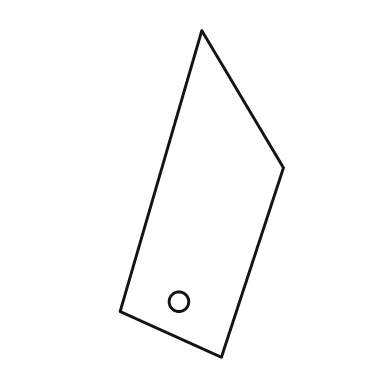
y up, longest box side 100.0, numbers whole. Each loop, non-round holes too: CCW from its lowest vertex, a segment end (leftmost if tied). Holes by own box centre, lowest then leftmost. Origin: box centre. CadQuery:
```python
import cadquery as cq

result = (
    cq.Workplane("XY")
    .moveTo(6.0, -50.0)
    .lineTo(25.0, 8.0)
    .lineTo(0.0, 50.0)
    .lineTo(-25.0, -36.0)
    .close()
    .moveTo(-7.0, -33.0)
    .circle(3.0)
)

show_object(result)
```